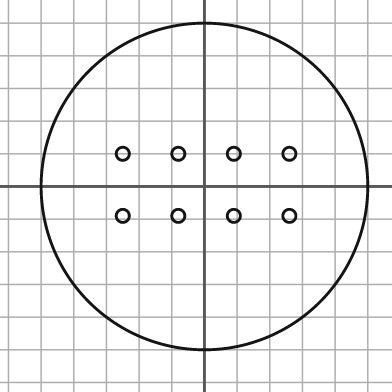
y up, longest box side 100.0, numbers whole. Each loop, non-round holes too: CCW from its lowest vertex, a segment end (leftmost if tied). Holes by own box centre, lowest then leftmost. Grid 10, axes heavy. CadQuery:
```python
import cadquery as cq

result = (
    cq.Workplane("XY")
    .moveTo(0.0, 0.0)
    .circle(50.0)
    .moveTo(-25.0, -9.0)
    .circle(2.0)
    .moveTo(-8.0, -9.0)
    .circle(2.0)
    .moveTo(9.0, -9.0)
    .circle(2.0)
    .moveTo(26.0, -9.0)
    .circle(2.0)
    .moveTo(-25.0, 10.0)
    .circle(2.0)
    .moveTo(-8.0, 10.0)
    .circle(2.0)
    .moveTo(9.0, 10.0)
    .circle(2.0)
    .moveTo(26.0, 10.0)
    .circle(2.0)
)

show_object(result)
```